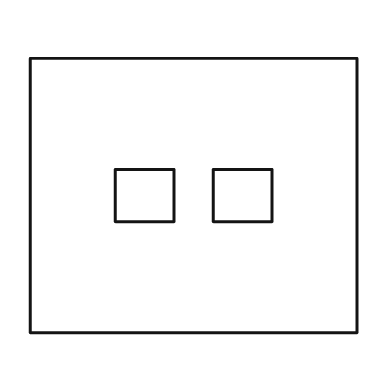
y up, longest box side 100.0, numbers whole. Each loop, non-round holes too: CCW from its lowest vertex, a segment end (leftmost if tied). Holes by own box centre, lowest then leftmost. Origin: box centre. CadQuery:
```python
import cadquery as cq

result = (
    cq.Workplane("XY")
    .moveTo(-50.0, -42.0)
    .lineTo(50.0, -42.0)
    .lineTo(50.0, 42.0)
    .lineTo(-50.0, 42.0)
    .close()
    .moveTo(-24.0, -8.0)
    .lineTo(-6.0, -8.0)
    .lineTo(-6.0, 8.0)
    .lineTo(-24.0, 8.0)
    .close()
    .moveTo(6.0, -8.0)
    .lineTo(24.0, -8.0)
    .lineTo(24.0, 8.0)
    .lineTo(6.0, 8.0)
    .close()
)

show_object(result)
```